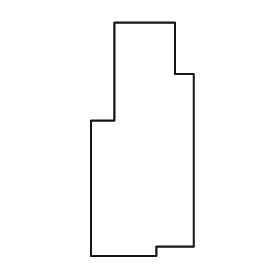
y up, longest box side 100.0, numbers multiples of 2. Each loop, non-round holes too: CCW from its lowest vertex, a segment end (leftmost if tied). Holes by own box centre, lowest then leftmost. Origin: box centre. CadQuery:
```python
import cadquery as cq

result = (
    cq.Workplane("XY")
    .moveTo(-22.0, -50.0)
    .lineTo(6.0, -50.0)
    .lineTo(6.0, -46.0)
    .lineTo(22.0, -46.0)
    .lineTo(22.0, 28.0)
    .lineTo(14.0, 28.0)
    .lineTo(14.0, 50.0)
    .lineTo(-12.0, 50.0)
    .lineTo(-12.0, 8.0)
    .lineTo(-22.0, 8.0)
    .close()
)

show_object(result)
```